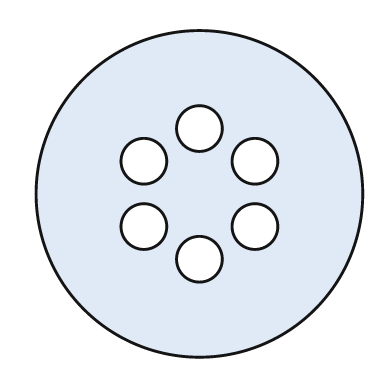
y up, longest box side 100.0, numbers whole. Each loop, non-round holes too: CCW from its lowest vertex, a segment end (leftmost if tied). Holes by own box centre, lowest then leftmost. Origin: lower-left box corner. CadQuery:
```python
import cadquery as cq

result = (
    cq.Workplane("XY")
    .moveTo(50.0, 50.0)
    .circle(50.0)
    .moveTo(50.0, 30.0)
    .circle(7.0)
    .moveTo(33.0, 40.0)
    .circle(7.0)
    .moveTo(67.0, 40.0)
    .circle(7.0)
    .moveTo(33.0, 60.0)
    .circle(7.0)
    .moveTo(67.0, 60.0)
    .circle(7.0)
    .moveTo(50.0, 70.0)
    .circle(7.0)
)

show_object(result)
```